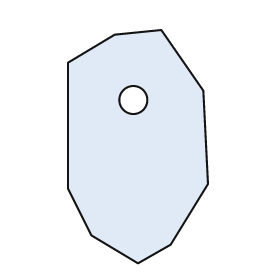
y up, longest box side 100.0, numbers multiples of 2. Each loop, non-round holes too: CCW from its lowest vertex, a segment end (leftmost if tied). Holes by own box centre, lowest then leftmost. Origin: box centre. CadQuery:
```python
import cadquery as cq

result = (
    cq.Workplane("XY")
    .moveTo(0.0, -50.0)
    .lineTo(14.0, -42.0)
    .lineTo(30.0, -16.0)
    .lineTo(28.0, 24.0)
    .lineTo(10.0, 50.0)
    .lineTo(-10.0, 48.0)
    .lineTo(-30.0, 36.0)
    .lineTo(-30.0, -18.0)
    .lineTo(-20.0, -38.0)
    .close()
    .moveTo(-2.0, 20.0)
    .circle(6.0)
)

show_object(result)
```